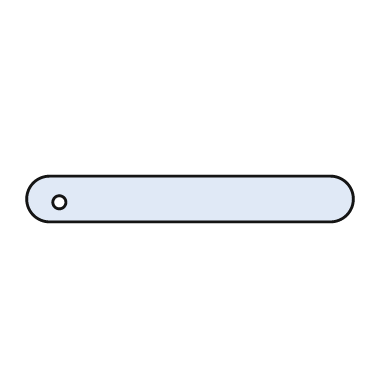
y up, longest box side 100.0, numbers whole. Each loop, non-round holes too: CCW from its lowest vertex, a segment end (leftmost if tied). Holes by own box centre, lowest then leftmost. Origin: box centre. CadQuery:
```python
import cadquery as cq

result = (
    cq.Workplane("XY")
    .moveTo(-43.0, -7.0)
    .lineTo(43.0, -7.0)
    .threePointArc((50.0, 0.0), (43.0, 7.0))
    .lineTo(-43.0, 7.0)
    .threePointArc((-50.0, 0.0), (-43.0, -7.0))
    .close()
    .moveTo(-40.0, -1.0)
    .circle(2.0)
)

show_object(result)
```